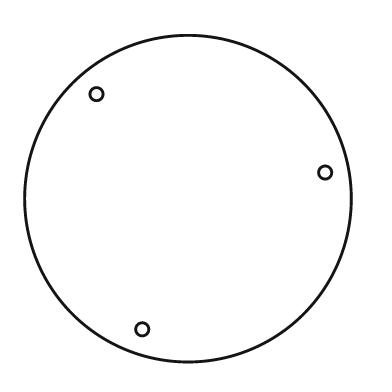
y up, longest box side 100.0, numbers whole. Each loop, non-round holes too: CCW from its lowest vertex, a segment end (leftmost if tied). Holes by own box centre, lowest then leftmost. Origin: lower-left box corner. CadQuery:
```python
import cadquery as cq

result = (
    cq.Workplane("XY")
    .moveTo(50.0, 50.0)
    .circle(50.0)
    .moveTo(36.0, 10.0)
    .circle(2.0)
    .moveTo(92.0, 58.0)
    .circle(2.0)
    .moveTo(22.0, 82.0)
    .circle(2.0)
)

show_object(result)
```